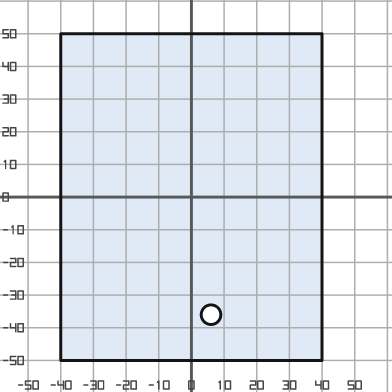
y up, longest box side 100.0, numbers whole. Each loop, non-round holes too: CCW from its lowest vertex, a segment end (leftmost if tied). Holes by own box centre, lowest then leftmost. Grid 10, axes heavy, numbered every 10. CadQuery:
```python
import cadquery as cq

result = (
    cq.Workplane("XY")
    .moveTo(-40.0, -50.0)
    .lineTo(40.0, -50.0)
    .lineTo(40.0, 50.0)
    .lineTo(-40.0, 50.0)
    .close()
    .moveTo(6.0, -36.0)
    .circle(3.0)
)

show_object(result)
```